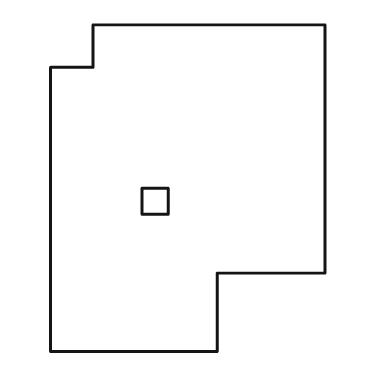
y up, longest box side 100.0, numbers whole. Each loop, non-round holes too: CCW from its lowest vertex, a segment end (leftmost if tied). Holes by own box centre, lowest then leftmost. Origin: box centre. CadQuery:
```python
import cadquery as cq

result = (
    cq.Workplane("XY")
    .moveTo(-42.0, -50.0)
    .lineTo(9.0, -50.0)
    .lineTo(9.0, -26.0)
    .lineTo(42.0, -26.0)
    .lineTo(42.0, 50.0)
    .lineTo(-29.0, 50.0)
    .lineTo(-29.0, 37.0)
    .lineTo(-42.0, 37.0)
    .close()
    .moveTo(-14.0, -8.0)
    .lineTo(-6.0, -8.0)
    .lineTo(-6.0, 0.0)
    .lineTo(-14.0, 0.0)
    .close()
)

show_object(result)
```